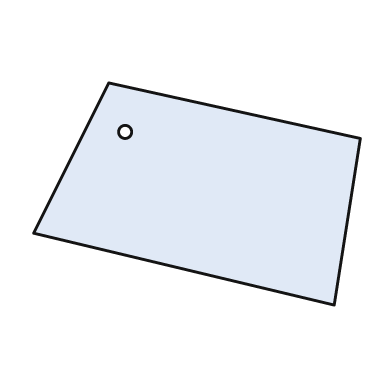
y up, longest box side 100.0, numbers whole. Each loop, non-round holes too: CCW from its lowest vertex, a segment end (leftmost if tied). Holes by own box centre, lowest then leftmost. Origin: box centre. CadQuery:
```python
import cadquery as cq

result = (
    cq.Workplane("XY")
    .moveTo(42.0, -34.0)
    .lineTo(50.0, 17.0)
    .lineTo(-27.0, 34.0)
    .lineTo(-50.0, -12.0)
    .close()
    .moveTo(-22.0, 19.0)
    .circle(2.0)
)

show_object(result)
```